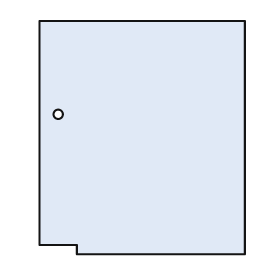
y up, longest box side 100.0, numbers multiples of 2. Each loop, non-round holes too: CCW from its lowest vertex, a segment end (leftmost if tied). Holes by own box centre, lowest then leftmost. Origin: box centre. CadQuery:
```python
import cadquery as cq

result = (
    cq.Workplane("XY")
    .moveTo(-28.0, -50.0)
    .lineTo(44.0, -50.0)
    .lineTo(44.0, 50.0)
    .lineTo(-44.0, 50.0)
    .lineTo(-44.0, -46.0)
    .lineTo(-28.0, -46.0)
    .close()
    .moveTo(-36.0, 10.0)
    .circle(2.0)
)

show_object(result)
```